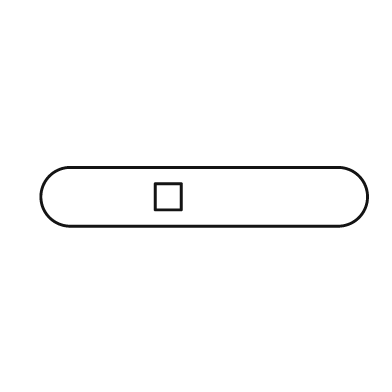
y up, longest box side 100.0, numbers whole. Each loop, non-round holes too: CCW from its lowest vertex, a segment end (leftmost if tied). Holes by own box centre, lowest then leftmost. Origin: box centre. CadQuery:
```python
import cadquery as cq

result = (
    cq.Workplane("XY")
    .moveTo(-41.0, -9.0)
    .lineTo(41.0, -9.0)
    .threePointArc((50.0, 0.0), (41.0, 9.0))
    .lineTo(-41.0, 9.0)
    .threePointArc((-50.0, 0.0), (-41.0, -9.0))
    .close()
    .moveTo(-15.0, -4.0)
    .lineTo(-7.0, -4.0)
    .lineTo(-7.0, 4.0)
    .lineTo(-15.0, 4.0)
    .close()
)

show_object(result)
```